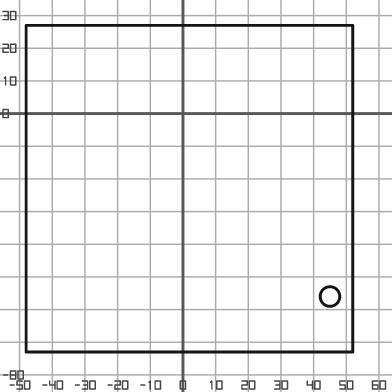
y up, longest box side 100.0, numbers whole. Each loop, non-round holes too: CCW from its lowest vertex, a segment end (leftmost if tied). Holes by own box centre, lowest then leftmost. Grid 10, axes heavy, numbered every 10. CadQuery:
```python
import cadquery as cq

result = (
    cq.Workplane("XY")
    .moveTo(-48.0, -73.0)
    .lineTo(52.0, -73.0)
    .lineTo(52.0, 27.0)
    .lineTo(-48.0, 27.0)
    .close()
    .moveTo(45.0, -56.0)
    .circle(3.0)
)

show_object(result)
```